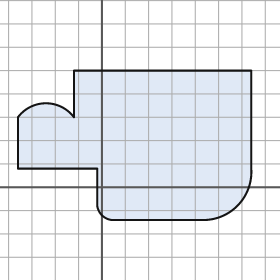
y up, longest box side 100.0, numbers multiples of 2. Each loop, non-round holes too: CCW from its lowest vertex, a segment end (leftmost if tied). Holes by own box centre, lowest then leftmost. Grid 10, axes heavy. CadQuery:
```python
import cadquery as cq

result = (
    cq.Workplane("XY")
    .moveTo(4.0, -14.0)
    .lineTo(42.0, -14.0)
    .threePointArc((58.0, -8.0), (64.0, 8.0))
    .lineTo(64.0, 50.0)
    .lineTo(-12.0, 50.0)
    .lineTo(-12.0, 30.0)
    .threePointArc((-24.0, 36.0), (-36.0, 30.0))
    .lineTo(-36.0, 8.0)
    .lineTo(-2.0, 8.0)
    .lineTo(-2.0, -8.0)
    .threePointArc((0.0, -12.0), (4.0, -14.0))
    .close()
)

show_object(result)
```